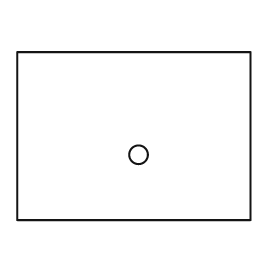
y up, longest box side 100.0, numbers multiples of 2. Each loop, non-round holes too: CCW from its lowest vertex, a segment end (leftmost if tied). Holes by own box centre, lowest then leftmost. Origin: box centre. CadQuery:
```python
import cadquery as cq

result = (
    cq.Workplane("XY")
    .moveTo(-50.0, -36.0)
    .lineTo(50.0, -36.0)
    .lineTo(50.0, 36.0)
    .lineTo(-50.0, 36.0)
    .close()
    .moveTo(2.0, -8.0)
    .circle(4.0)
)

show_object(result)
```